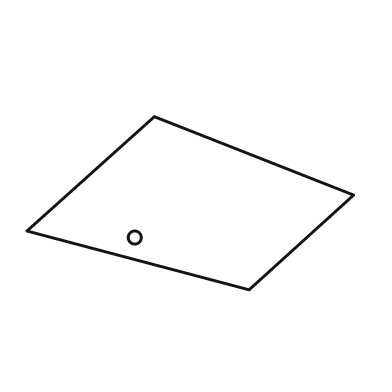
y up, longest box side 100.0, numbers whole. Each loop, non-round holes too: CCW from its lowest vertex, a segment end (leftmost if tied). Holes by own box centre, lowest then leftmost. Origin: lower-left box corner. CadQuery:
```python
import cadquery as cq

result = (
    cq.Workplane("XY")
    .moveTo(68.0, 0.0)
    .lineTo(100.0, 29.0)
    .lineTo(39.0, 53.0)
    .lineTo(0.0, 18.0)
    .close()
    .moveTo(33.0, 16.0)
    .circle(2.0)
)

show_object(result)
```